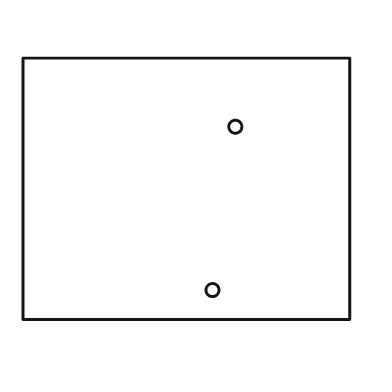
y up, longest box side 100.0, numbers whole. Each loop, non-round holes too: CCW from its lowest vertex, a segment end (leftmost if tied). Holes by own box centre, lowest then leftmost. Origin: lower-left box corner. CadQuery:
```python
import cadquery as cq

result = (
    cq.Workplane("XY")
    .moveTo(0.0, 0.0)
    .lineTo(100.0, 0.0)
    .lineTo(100.0, 80.0)
    .lineTo(0.0, 80.0)
    .close()
    .moveTo(58.0, 9.0)
    .circle(2.0)
    .moveTo(65.0, 59.0)
    .circle(2.0)
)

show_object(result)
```